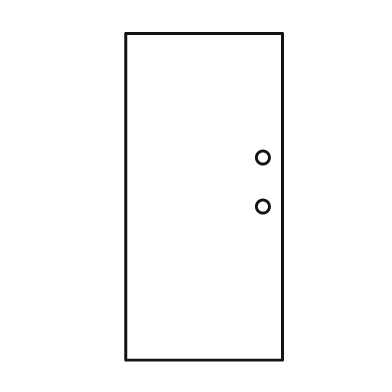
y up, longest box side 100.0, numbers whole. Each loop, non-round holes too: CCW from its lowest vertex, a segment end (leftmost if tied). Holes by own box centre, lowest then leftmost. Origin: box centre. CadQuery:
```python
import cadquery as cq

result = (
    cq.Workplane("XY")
    .moveTo(-24.0, -50.0)
    .lineTo(24.0, -50.0)
    .lineTo(24.0, 50.0)
    .lineTo(-24.0, 50.0)
    .close()
    .moveTo(18.0, -3.0)
    .circle(2.0)
    .moveTo(18.0, 12.0)
    .circle(2.0)
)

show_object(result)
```